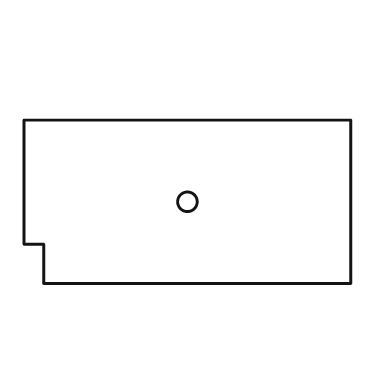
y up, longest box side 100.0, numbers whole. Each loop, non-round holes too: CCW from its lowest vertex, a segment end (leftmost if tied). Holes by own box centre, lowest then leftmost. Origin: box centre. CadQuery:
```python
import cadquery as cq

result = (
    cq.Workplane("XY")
    .moveTo(-44.0, -25.0)
    .lineTo(50.0, -25.0)
    .lineTo(50.0, 25.0)
    .lineTo(-50.0, 25.0)
    .lineTo(-50.0, -13.0)
    .lineTo(-44.0, -13.0)
    .close()
    .moveTo(0.0, 0.0)
    .circle(3.0)
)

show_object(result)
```